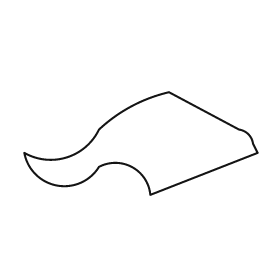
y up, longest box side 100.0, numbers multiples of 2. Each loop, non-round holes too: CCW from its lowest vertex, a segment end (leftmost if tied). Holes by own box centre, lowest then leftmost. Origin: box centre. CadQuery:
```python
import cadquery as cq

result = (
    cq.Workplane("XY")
    .moveTo(4.0, -22.0)
    .lineTo(50.0, -4.0)
    .lineTo(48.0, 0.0)
    .threePointArc((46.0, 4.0), (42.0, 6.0))
    .lineTo(12.0, 22.0)
    .threePointArc((-4.0, 16.0), (-18.0, 6.0))
    .threePointArc((-32.0, -6.0), (-50.0, -4.0))
    .threePointArc((-36.0, -18.0), (-18.0, -10.0))
    .threePointArc((-4.0, -10.0), (4.0, -22.0))
    .close()
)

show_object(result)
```